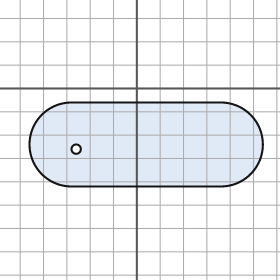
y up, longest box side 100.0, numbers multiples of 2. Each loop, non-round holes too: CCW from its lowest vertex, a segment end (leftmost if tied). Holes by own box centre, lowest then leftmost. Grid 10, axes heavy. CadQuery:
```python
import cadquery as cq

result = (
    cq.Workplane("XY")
    .moveTo(-28.0, -42.0)
    .lineTo(36.0, -42.0)
    .threePointArc((54.0, -24.0), (36.0, -6.0))
    .lineTo(-28.0, -6.0)
    .threePointArc((-46.0, -24.0), (-28.0, -42.0))
    .close()
    .moveTo(-26.0, -26.0)
    .circle(2.0)
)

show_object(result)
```